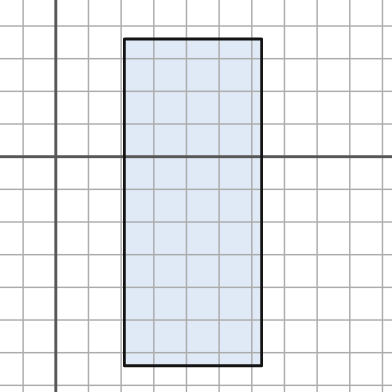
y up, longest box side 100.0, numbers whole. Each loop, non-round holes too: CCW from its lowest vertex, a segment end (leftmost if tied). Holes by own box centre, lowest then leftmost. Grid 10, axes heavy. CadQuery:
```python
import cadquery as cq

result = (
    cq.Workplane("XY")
    .moveTo(21.0, -64.0)
    .lineTo(63.0, -64.0)
    .lineTo(63.0, 36.0)
    .lineTo(21.0, 36.0)
    .close()
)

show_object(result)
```